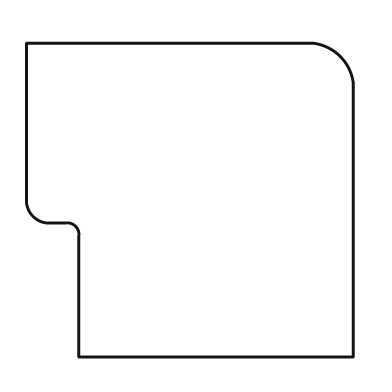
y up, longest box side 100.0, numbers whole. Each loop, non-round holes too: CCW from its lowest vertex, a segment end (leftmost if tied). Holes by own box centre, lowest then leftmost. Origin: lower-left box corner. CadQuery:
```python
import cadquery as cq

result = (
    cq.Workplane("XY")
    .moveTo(16.0, 0.0)
    .lineTo(100.0, 0.0)
    .lineTo(100.0, 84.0)
    .threePointArc((96.0, 92.0), (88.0, 96.0))
    .lineTo(0.0, 96.0)
    .lineTo(0.0, 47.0)
    .threePointArc((2.0, 43.0), (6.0, 41.0))
    .lineTo(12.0, 41.0)
    .threePointArc((15.0, 40.0), (16.0, 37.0))
    .close()
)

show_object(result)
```